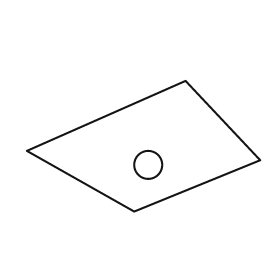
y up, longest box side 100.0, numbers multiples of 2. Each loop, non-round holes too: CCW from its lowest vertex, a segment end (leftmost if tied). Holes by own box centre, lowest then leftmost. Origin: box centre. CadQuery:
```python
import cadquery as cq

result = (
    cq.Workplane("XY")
    .moveTo(-4.0, -28.0)
    .lineTo(50.0, -6.0)
    .lineTo(18.0, 28.0)
    .lineTo(-50.0, -2.0)
    .close()
    .moveTo(2.0, -8.0)
    .circle(6.0)
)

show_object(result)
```